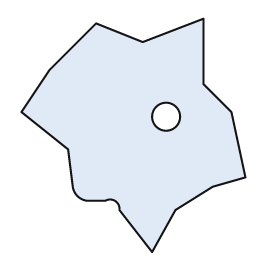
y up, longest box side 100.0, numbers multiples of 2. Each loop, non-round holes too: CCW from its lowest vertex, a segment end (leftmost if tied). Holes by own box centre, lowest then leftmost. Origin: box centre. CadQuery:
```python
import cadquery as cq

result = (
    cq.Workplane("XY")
    .moveTo(8.0, -50.0)
    .lineTo(18.0, -32.0)
    .lineTo(34.0, -22.0)
    .lineTo(48.0, -18.0)
    .lineTo(42.0, 10.0)
    .lineTo(30.0, 22.0)
    .lineTo(30.0, 50.0)
    .lineTo(4.0, 40.0)
    .lineTo(-16.0, 48.0)
    .lineTo(-36.0, 28.0)
    .lineTo(-48.0, 10.0)
    .lineTo(-28.0, -6.0)
    .lineTo(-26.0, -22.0)
    .threePointArc((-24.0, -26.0), (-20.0, -28.0))
    .lineTo(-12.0, -28.0)
    .threePointArc((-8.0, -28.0), (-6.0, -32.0))
    .close()
    .moveTo(14.0, 8.0)
    .circle(6.0)
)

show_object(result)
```